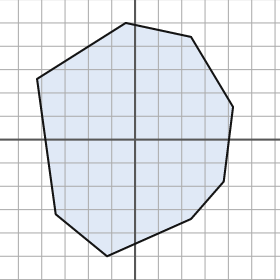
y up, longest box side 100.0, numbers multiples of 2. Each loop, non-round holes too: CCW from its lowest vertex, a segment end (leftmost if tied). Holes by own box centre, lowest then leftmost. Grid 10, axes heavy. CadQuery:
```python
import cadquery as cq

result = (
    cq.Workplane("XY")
    .moveTo(-12.0, -50.0)
    .lineTo(24.0, -34.0)
    .lineTo(38.0, -18.0)
    .lineTo(42.0, 14.0)
    .lineTo(24.0, 44.0)
    .lineTo(-4.0, 50.0)
    .lineTo(-42.0, 26.0)
    .lineTo(-34.0, -32.0)
    .close()
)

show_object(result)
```